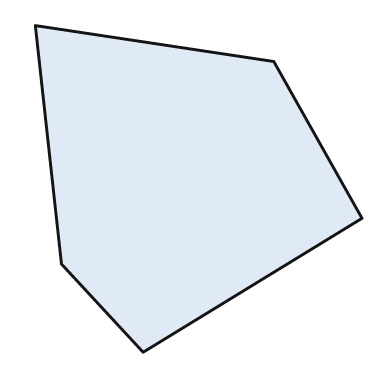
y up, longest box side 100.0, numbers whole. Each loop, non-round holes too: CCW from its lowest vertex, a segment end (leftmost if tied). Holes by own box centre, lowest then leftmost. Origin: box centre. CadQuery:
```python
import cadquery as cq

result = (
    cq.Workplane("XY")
    .moveTo(-17.0, -50.0)
    .lineTo(50.0, -9.0)
    .lineTo(23.0, 39.0)
    .lineTo(-50.0, 50.0)
    .lineTo(-42.0, -23.0)
    .close()
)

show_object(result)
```